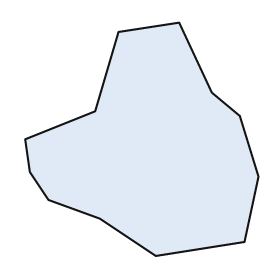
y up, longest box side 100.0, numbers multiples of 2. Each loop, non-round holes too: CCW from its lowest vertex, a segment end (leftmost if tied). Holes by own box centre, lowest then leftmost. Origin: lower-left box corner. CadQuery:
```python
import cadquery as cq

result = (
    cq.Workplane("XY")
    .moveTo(56.0, 0.0)
    .lineTo(94.0, 6.0)
    .lineTo(100.0, 34.0)
    .lineTo(92.0, 60.0)
    .lineTo(80.0, 70.0)
    .lineTo(66.0, 100.0)
    .lineTo(40.0, 96.0)
    .lineTo(30.0, 62.0)
    .lineTo(0.0, 50.0)
    .lineTo(2.0, 36.0)
    .lineTo(10.0, 24.0)
    .lineTo(32.0, 16.0)
    .close()
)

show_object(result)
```